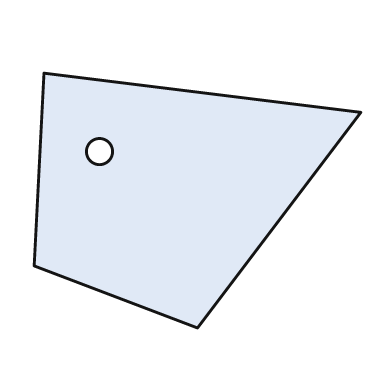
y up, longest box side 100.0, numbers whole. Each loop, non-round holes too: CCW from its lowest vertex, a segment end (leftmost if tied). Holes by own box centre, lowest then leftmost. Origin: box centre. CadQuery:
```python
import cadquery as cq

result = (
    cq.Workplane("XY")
    .moveTo(0.0, -39.0)
    .lineTo(50.0, 27.0)
    .lineTo(-47.0, 39.0)
    .lineTo(-50.0, -20.0)
    .close()
    .moveTo(-30.0, 15.0)
    .circle(4.0)
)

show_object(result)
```